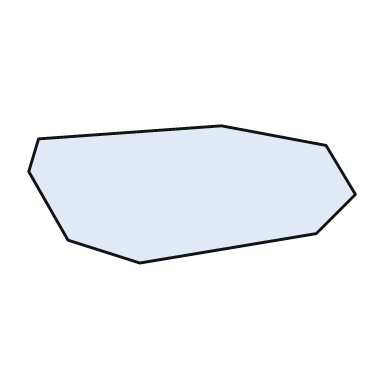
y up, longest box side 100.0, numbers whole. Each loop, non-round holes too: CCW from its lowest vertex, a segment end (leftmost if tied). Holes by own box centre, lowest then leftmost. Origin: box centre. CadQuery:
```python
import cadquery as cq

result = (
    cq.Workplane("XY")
    .moveTo(-16.0, -21.0)
    .lineTo(38.0, -12.0)
    .lineTo(50.0, 0.0)
    .lineTo(41.0, 15.0)
    .lineTo(9.0, 21.0)
    .lineTo(-47.0, 17.0)
    .lineTo(-50.0, 7.0)
    .lineTo(-38.0, -14.0)
    .close()
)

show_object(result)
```